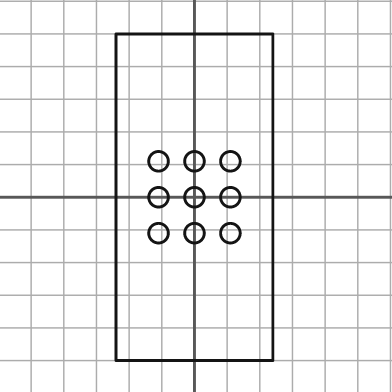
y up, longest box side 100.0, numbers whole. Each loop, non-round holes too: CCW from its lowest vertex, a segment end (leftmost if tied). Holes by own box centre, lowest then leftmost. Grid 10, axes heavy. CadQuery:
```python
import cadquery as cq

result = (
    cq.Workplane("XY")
    .moveTo(-24.0, -50.0)
    .lineTo(24.0, -50.0)
    .lineTo(24.0, 50.0)
    .lineTo(-24.0, 50.0)
    .close()
    .moveTo(-11.0, -11.0)
    .circle(3.0)
    .moveTo(0.0, -11.0)
    .circle(3.0)
    .moveTo(11.0, -11.0)
    .circle(3.0)
    .moveTo(-11.0, 0.0)
    .circle(3.0)
    .moveTo(0.0, 0.0)
    .circle(3.0)
    .moveTo(11.0, 0.0)
    .circle(3.0)
    .moveTo(-11.0, 11.0)
    .circle(3.0)
    .moveTo(0.0, 11.0)
    .circle(3.0)
    .moveTo(11.0, 11.0)
    .circle(3.0)
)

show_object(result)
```